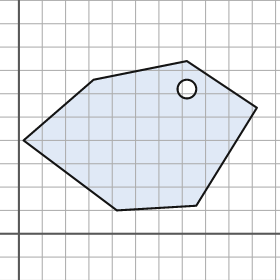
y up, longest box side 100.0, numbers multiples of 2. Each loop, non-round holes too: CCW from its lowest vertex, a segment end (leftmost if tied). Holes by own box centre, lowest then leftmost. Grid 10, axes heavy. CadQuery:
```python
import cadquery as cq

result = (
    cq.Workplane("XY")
    .moveTo(42.0, 10.0)
    .lineTo(76.0, 12.0)
    .lineTo(102.0, 54.0)
    .lineTo(72.0, 74.0)
    .lineTo(32.0, 66.0)
    .lineTo(2.0, 40.0)
    .close()
    .moveTo(72.0, 62.0)
    .circle(4.0)
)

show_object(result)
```